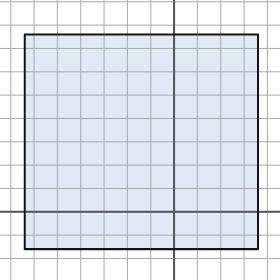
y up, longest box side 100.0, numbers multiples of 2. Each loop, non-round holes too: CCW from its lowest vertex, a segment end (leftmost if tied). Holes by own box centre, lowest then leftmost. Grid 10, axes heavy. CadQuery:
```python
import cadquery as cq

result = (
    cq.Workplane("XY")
    .moveTo(-64.0, -16.0)
    .lineTo(36.0, -16.0)
    .lineTo(36.0, 76.0)
    .lineTo(-64.0, 76.0)
    .close()
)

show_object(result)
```